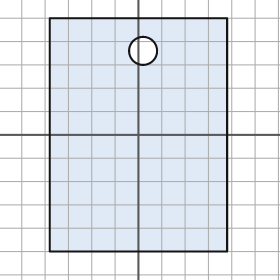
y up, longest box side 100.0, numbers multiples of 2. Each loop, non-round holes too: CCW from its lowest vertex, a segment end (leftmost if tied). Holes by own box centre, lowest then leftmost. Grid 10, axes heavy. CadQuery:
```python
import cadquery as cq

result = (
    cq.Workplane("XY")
    .moveTo(-38.0, -50.0)
    .lineTo(38.0, -50.0)
    .lineTo(38.0, 50.0)
    .lineTo(-38.0, 50.0)
    .close()
    .moveTo(2.0, 36.0)
    .circle(6.0)
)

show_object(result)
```